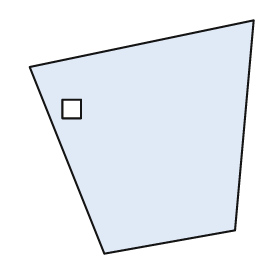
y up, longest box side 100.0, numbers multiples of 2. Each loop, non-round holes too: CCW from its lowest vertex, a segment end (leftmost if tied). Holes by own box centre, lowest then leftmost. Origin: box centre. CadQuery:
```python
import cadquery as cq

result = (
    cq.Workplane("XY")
    .moveTo(-16.0, -50.0)
    .lineTo(40.0, -40.0)
    .lineTo(48.0, 50.0)
    .lineTo(-48.0, 30.0)
    .close()
    .moveTo(-34.0, 8.0)
    .lineTo(-26.0, 8.0)
    .lineTo(-26.0, 16.0)
    .lineTo(-34.0, 16.0)
    .close()
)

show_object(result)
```